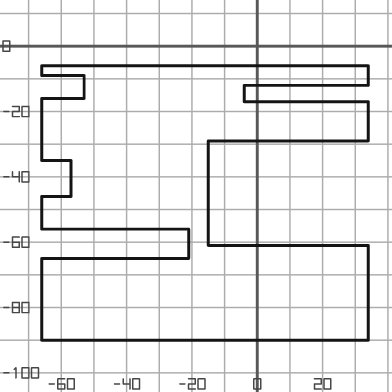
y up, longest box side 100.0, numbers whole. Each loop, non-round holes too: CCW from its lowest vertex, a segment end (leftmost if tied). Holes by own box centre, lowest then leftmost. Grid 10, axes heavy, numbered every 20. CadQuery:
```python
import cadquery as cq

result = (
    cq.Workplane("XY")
    .moveTo(-66.0, -90.0)
    .lineTo(34.0, -90.0)
    .lineTo(34.0, -61.0)
    .lineTo(-15.0, -61.0)
    .lineTo(-15.0, -29.0)
    .lineTo(34.0, -29.0)
    .lineTo(34.0, -17.0)
    .lineTo(-4.0, -17.0)
    .lineTo(-4.0, -12.0)
    .lineTo(34.0, -12.0)
    .lineTo(34.0, -6.0)
    .lineTo(-66.0, -6.0)
    .lineTo(-66.0, -9.0)
    .lineTo(-53.0, -9.0)
    .lineTo(-53.0, -16.0)
    .lineTo(-66.0, -16.0)
    .lineTo(-66.0, -35.0)
    .lineTo(-57.0, -35.0)
    .lineTo(-57.0, -46.0)
    .lineTo(-66.0, -46.0)
    .lineTo(-66.0, -56.0)
    .lineTo(-21.0, -56.0)
    .lineTo(-21.0, -65.0)
    .lineTo(-66.0, -65.0)
    .close()
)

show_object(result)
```